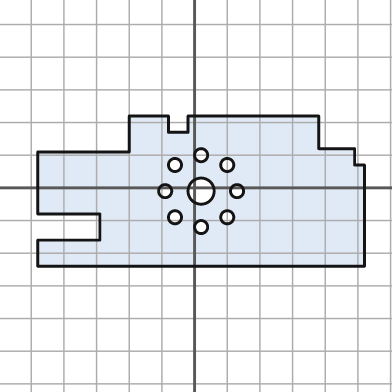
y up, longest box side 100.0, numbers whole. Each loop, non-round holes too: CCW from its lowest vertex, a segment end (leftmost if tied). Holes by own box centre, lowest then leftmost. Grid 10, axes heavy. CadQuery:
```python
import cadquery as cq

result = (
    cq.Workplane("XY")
    .moveTo(-48.0, -24.0)
    .lineTo(52.0, -24.0)
    .lineTo(52.0, 7.0)
    .lineTo(49.0, 7.0)
    .lineTo(49.0, 12.0)
    .lineTo(38.0, 12.0)
    .lineTo(38.0, 22.0)
    .lineTo(-2.0, 22.0)
    .lineTo(-2.0, 17.0)
    .lineTo(-8.0, 17.0)
    .lineTo(-8.0, 22.0)
    .lineTo(-20.0, 22.0)
    .lineTo(-20.0, 11.0)
    .lineTo(-48.0, 11.0)
    .lineTo(-48.0, -8.0)
    .lineTo(-29.0, -8.0)
    .lineTo(-29.0, -16.0)
    .lineTo(-48.0, -16.0)
    .close()
    .moveTo(2.0, -12.0)
    .circle(2.0)
    .moveTo(-6.0, -9.0)
    .circle(2.0)
    .moveTo(10.0, -9.0)
    .circle(2.0)
    .moveTo(-9.0, -1.0)
    .circle(2.0)
    .moveTo(2.0, -1.0)
    .circle(4.0)
    .moveTo(13.0, -1.0)
    .circle(2.0)
    .moveTo(-6.0, 7.0)
    .circle(2.0)
    .moveTo(10.0, 7.0)
    .circle(2.0)
    .moveTo(2.0, 10.0)
    .circle(2.0)
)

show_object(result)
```